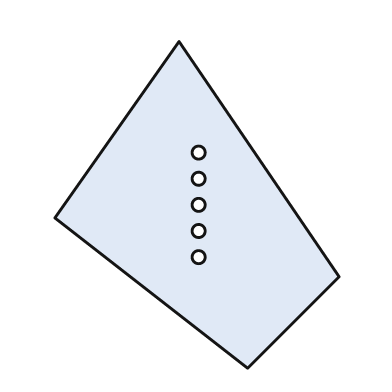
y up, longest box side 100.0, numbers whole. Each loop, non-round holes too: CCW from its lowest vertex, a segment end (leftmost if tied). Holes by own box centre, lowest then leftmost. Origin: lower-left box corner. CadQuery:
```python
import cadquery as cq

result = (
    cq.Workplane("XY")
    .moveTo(59.0, 0.0)
    .lineTo(87.0, 28.0)
    .lineTo(38.0, 100.0)
    .lineTo(0.0, 46.0)
    .close()
    .moveTo(44.0, 34.0)
    .circle(2.0)
    .moveTo(44.0, 42.0)
    .circle(2.0)
    .moveTo(44.0, 50.0)
    .circle(2.0)
    .moveTo(44.0, 58.0)
    .circle(2.0)
    .moveTo(44.0, 66.0)
    .circle(2.0)
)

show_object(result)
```